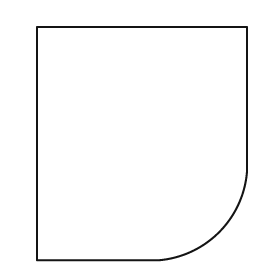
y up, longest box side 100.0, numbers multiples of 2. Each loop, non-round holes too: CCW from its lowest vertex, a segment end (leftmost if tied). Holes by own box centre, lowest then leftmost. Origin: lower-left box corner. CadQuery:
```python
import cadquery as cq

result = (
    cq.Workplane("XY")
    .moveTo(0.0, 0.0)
    .lineTo(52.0, 0.0)
    .threePointArc((78.0, 12.0), (90.0, 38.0))
    .lineTo(90.0, 100.0)
    .lineTo(0.0, 100.0)
    .close()
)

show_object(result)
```